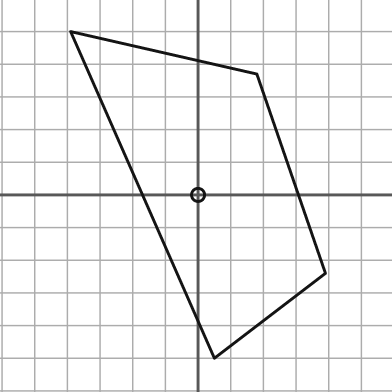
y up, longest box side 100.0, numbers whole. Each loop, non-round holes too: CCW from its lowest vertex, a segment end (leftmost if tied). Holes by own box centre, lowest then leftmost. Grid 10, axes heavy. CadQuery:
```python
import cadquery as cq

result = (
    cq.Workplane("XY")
    .moveTo(5.0, -50.0)
    .lineTo(39.0, -24.0)
    .lineTo(18.0, 37.0)
    .lineTo(-39.0, 50.0)
    .close()
    .moveTo(0.0, 0.0)
    .circle(2.0)
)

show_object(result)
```